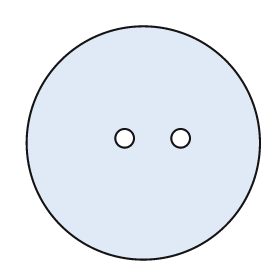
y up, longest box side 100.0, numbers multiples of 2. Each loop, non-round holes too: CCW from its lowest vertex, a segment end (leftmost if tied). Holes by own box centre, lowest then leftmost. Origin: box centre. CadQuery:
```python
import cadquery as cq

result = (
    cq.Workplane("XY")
    .moveTo(0.0, 0.0)
    .circle(50.0)
    .moveTo(-8.0, 2.0)
    .circle(4.0)
    .moveTo(16.0, 2.0)
    .circle(4.0)
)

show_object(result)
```